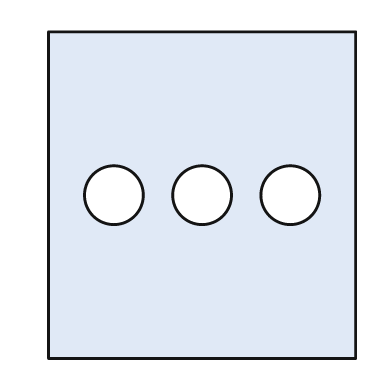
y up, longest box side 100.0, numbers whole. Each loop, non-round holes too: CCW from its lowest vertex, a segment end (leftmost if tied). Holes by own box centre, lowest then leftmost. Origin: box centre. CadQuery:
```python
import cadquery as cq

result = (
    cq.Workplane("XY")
    .moveTo(-47.0, -50.0)
    .lineTo(47.0, -50.0)
    .lineTo(47.0, 50.0)
    .lineTo(-47.0, 50.0)
    .close()
    .moveTo(-27.0, 0.0)
    .circle(9.0)
    .moveTo(0.0, 0.0)
    .circle(9.0)
    .moveTo(27.0, 0.0)
    .circle(9.0)
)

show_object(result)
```